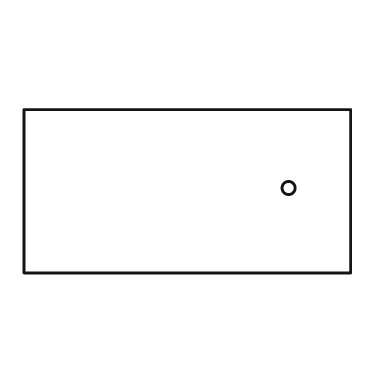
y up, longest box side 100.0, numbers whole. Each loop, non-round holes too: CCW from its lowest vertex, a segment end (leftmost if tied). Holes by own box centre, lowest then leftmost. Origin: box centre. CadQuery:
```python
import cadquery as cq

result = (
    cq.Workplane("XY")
    .moveTo(-50.0, -25.0)
    .lineTo(50.0, -25.0)
    .lineTo(50.0, 25.0)
    .lineTo(-50.0, 25.0)
    .close()
    .moveTo(31.0, 1.0)
    .circle(2.0)
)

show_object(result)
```